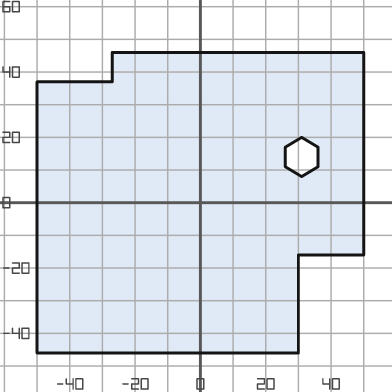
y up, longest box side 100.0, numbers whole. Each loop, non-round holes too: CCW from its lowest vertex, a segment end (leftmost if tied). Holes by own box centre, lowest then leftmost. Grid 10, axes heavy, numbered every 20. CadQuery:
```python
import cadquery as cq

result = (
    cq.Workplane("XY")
    .moveTo(-50.0, -46.0)
    .lineTo(30.0, -46.0)
    .lineTo(30.0, -16.0)
    .lineTo(50.0, -16.0)
    .lineTo(50.0, 46.0)
    .lineTo(-27.0, 46.0)
    .lineTo(-27.0, 37.0)
    .lineTo(-50.0, 37.0)
    .close()
    .moveTo(31.0, 8.0)
    .lineTo(36.0, 11.0)
    .lineTo(36.0, 17.0)
    .lineTo(31.0, 20.0)
    .lineTo(26.0, 17.0)
    .lineTo(26.0, 11.0)
    .close()
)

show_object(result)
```